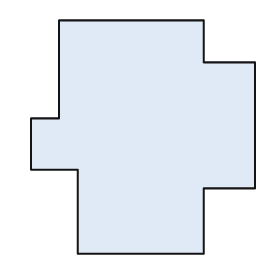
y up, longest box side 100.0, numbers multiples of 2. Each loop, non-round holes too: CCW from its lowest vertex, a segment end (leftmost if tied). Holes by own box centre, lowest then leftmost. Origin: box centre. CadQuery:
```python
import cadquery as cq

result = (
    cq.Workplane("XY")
    .moveTo(-28.0, -50.0)
    .lineTo(26.0, -50.0)
    .lineTo(26.0, -22.0)
    .lineTo(48.0, -22.0)
    .lineTo(48.0, 32.0)
    .lineTo(26.0, 32.0)
    .lineTo(26.0, 50.0)
    .lineTo(-36.0, 50.0)
    .lineTo(-36.0, 8.0)
    .lineTo(-48.0, 8.0)
    .lineTo(-48.0, -14.0)
    .lineTo(-28.0, -14.0)
    .close()
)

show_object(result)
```